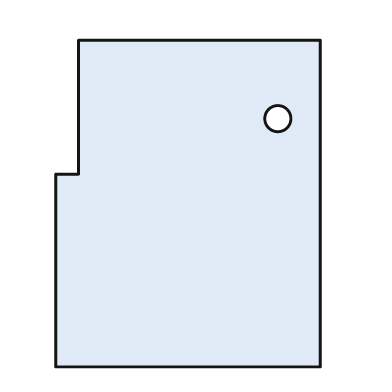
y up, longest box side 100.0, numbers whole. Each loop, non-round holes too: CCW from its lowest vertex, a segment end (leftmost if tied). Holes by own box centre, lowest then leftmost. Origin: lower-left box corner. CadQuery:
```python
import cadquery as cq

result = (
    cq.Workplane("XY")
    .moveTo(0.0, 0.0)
    .lineTo(81.0, 0.0)
    .lineTo(81.0, 100.0)
    .lineTo(7.0, 100.0)
    .lineTo(7.0, 59.0)
    .lineTo(0.0, 59.0)
    .close()
    .moveTo(68.0, 76.0)
    .circle(4.0)
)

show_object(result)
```